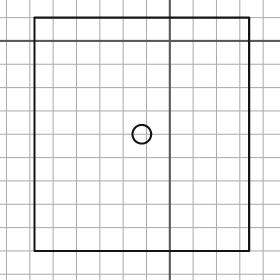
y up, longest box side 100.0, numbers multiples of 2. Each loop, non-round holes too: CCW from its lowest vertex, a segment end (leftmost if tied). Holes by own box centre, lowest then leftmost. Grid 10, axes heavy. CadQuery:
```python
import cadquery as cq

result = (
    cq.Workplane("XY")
    .moveTo(-58.0, -90.0)
    .lineTo(34.0, -90.0)
    .lineTo(34.0, 10.0)
    .lineTo(-58.0, 10.0)
    .close()
    .moveTo(-12.0, -40.0)
    .circle(4.0)
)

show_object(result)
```